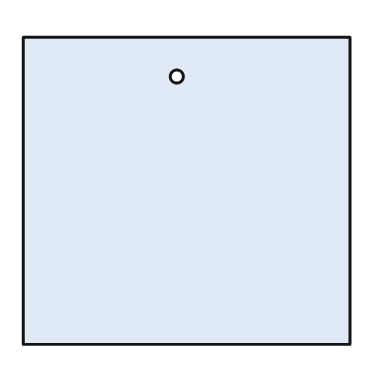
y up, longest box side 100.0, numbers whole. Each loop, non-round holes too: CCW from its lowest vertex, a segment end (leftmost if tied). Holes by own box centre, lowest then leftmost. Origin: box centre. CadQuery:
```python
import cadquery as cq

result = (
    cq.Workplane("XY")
    .moveTo(-50.0, -47.0)
    .lineTo(50.0, -47.0)
    .lineTo(50.0, 47.0)
    .lineTo(-50.0, 47.0)
    .close()
    .moveTo(-3.0, 35.0)
    .circle(2.0)
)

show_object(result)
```